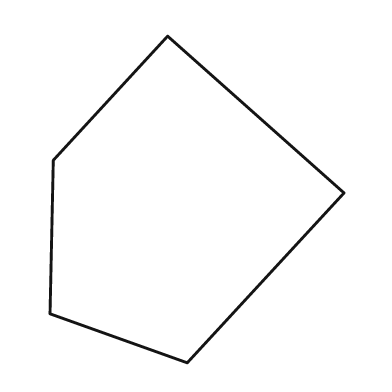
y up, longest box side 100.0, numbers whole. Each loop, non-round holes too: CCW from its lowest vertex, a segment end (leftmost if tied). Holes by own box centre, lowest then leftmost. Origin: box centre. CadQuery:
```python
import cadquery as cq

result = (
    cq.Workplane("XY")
    .moveTo(-3.0, -50.0)
    .lineTo(45.0, 2.0)
    .lineTo(-9.0, 50.0)
    .lineTo(-44.0, 12.0)
    .lineTo(-45.0, -35.0)
    .close()
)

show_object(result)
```